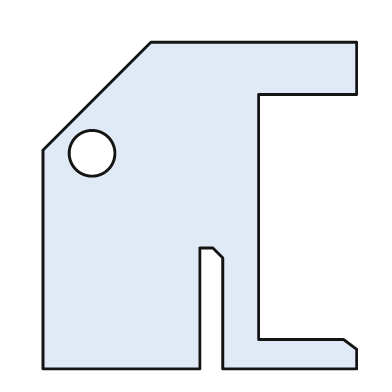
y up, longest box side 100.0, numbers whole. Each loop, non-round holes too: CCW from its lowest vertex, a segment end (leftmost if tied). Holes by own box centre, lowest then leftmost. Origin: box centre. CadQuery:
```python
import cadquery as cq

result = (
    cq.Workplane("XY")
    .moveTo(-48.0, -50.0)
    .lineTo(0.0, -50.0)
    .lineTo(0.0, -13.0)
    .lineTo(4.0, -13.0)
    .lineTo(7.0, -16.0)
    .lineTo(7.0, -50.0)
    .lineTo(48.0, -50.0)
    .lineTo(48.0, -44.0)
    .lineTo(44.0, -41.0)
    .lineTo(18.0, -41.0)
    .lineTo(18.0, 34.0)
    .lineTo(48.0, 34.0)
    .lineTo(48.0, 50.0)
    .lineTo(-15.0, 50.0)
    .lineTo(-48.0, 17.0)
    .close()
    .moveTo(-33.0, 16.0)
    .circle(7.0)
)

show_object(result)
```